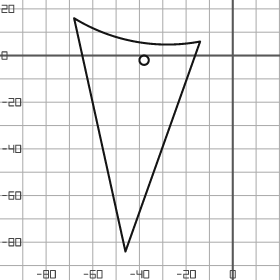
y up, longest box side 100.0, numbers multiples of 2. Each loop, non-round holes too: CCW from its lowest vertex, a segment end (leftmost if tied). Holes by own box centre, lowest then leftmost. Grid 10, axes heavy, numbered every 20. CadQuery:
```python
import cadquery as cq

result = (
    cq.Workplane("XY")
    .moveTo(-46.0, -84.0)
    .lineTo(-14.0, 6.0)
    .threePointArc((-42.0, 6.0), (-68.0, 16.0))
    .close()
    .moveTo(-38.0, -2.0)
    .circle(2.0)
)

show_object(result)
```